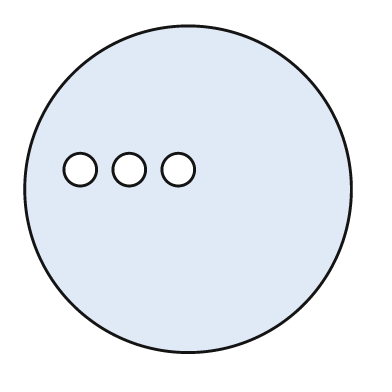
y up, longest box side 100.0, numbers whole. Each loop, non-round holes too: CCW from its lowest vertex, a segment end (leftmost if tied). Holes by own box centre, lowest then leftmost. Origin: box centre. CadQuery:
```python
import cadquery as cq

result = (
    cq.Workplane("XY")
    .moveTo(0.0, 0.0)
    .circle(50.0)
    .moveTo(-33.0, 6.0)
    .circle(5.0)
    .moveTo(-18.0, 6.0)
    .circle(5.0)
    .moveTo(-3.0, 6.0)
    .circle(5.0)
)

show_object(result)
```